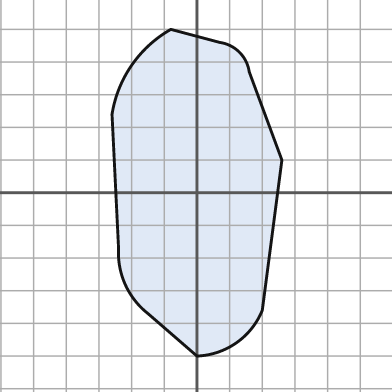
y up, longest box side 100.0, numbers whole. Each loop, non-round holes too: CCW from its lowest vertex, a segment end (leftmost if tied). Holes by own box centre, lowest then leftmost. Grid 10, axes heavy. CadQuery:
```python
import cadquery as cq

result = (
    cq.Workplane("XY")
    .moveTo(0.0, -50.0)
    .threePointArc((12.0, -46.0), (20.0, -36.0))
    .lineTo(26.0, 10.0)
    .lineTo(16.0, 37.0)
    .threePointArc((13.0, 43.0), (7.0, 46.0))
    .lineTo(-8.0, 50.0)
    .threePointArc((-20.0, 39.0), (-26.0, 24.0))
    .lineTo(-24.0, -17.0)
    .threePointArc((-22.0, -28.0), (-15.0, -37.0))
    .close()
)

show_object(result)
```